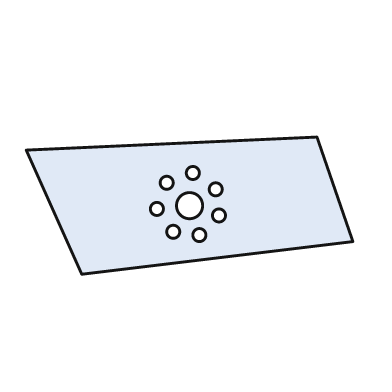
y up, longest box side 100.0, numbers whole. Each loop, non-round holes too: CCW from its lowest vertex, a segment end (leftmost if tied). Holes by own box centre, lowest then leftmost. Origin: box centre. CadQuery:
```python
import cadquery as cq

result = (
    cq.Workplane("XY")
    .moveTo(-33.0, -21.0)
    .lineTo(50.0, -11.0)
    .lineTo(39.0, 21.0)
    .lineTo(-50.0, 17.0)
    .close()
    .moveTo(3.0, -9.0)
    .circle(2.0)
    .moveTo(-5.0, -8.0)
    .circle(2.0)
    .moveTo(9.0, -3.0)
    .circle(2.0)
    .moveTo(-10.0, -1.0)
    .circle(2.0)
    .moveTo(0.0, 0.0)
    .circle(4.0)
    .moveTo(8.0, 5.0)
    .circle(2.0)
    .moveTo(-7.0, 7.0)
    .circle(2.0)
    .moveTo(1.0, 10.0)
    .circle(2.0)
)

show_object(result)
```